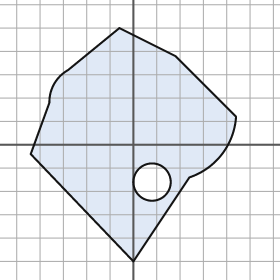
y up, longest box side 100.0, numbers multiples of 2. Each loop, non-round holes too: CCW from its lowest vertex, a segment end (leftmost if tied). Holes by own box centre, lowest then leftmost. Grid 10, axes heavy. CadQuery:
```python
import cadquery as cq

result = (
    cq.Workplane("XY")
    .moveTo(0.0, -50.0)
    .lineTo(24.0, -14.0)
    .threePointArc((38.0, -4.0), (44.0, 12.0))
    .lineTo(18.0, 38.0)
    .lineTo(-6.0, 50.0)
    .lineTo(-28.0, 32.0)
    .threePointArc((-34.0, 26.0), (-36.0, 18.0))
    .lineTo(-44.0, -4.0)
    .close()
    .moveTo(8.0, -16.0)
    .circle(8.0)
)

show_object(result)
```